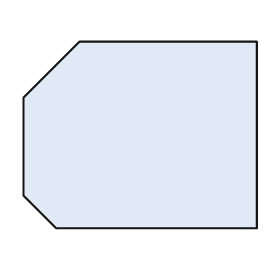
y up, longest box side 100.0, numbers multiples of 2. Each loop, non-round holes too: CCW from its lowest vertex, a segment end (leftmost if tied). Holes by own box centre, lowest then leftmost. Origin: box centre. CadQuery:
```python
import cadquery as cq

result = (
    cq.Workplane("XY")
    .moveTo(-36.0, -40.0)
    .lineTo(50.0, -40.0)
    .lineTo(50.0, 40.0)
    .lineTo(-26.0, 40.0)
    .lineTo(-50.0, 16.0)
    .lineTo(-50.0, -26.0)
    .close()
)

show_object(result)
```